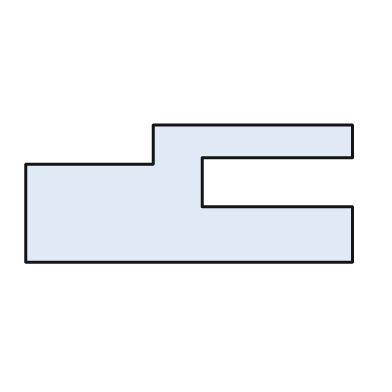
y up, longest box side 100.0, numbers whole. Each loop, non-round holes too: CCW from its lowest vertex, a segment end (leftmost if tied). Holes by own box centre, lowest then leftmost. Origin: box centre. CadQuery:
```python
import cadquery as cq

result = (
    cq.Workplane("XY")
    .moveTo(-50.0, -21.0)
    .lineTo(50.0, -21.0)
    .lineTo(50.0, -4.0)
    .lineTo(4.0, -4.0)
    .lineTo(4.0, 11.0)
    .lineTo(50.0, 11.0)
    .lineTo(50.0, 21.0)
    .lineTo(-11.0, 21.0)
    .lineTo(-11.0, 9.0)
    .lineTo(-50.0, 9.0)
    .close()
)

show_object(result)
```